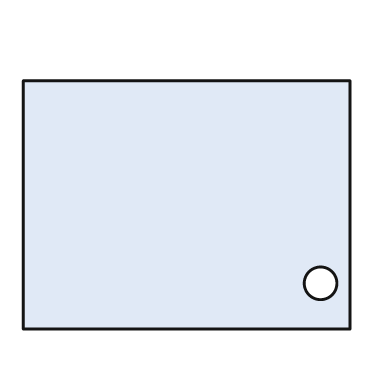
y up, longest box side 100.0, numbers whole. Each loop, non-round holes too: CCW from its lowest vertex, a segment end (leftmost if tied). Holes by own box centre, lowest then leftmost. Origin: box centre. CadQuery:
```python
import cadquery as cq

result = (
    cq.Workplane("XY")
    .moveTo(-50.0, -38.0)
    .lineTo(50.0, -38.0)
    .lineTo(50.0, 38.0)
    .lineTo(-50.0, 38.0)
    .close()
    .moveTo(41.0, -24.0)
    .circle(5.0)
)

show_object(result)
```